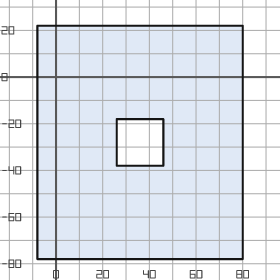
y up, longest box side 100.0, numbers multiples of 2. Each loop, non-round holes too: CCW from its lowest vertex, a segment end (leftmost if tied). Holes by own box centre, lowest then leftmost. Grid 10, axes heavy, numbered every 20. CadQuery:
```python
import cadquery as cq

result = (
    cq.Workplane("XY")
    .moveTo(-8.0, -78.0)
    .lineTo(80.0, -78.0)
    .lineTo(80.0, 22.0)
    .lineTo(-8.0, 22.0)
    .close()
    .moveTo(26.0, -38.0)
    .lineTo(46.0, -38.0)
    .lineTo(46.0, -18.0)
    .lineTo(26.0, -18.0)
    .close()
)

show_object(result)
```